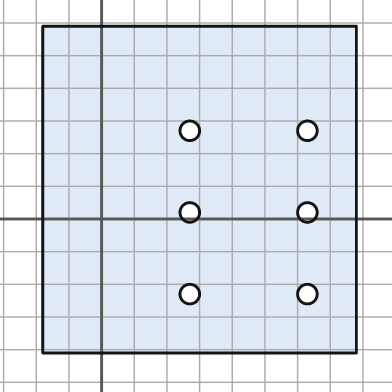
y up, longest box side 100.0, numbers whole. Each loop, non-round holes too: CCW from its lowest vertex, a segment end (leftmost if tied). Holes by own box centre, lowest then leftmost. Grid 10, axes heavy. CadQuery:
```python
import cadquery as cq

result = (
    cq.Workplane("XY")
    .moveTo(-18.0, -41.0)
    .lineTo(78.0, -41.0)
    .lineTo(78.0, 59.0)
    .lineTo(-18.0, 59.0)
    .close()
    .moveTo(27.0, -23.0)
    .circle(3.0)
    .moveTo(63.0, -23.0)
    .circle(3.0)
    .moveTo(27.0, 2.0)
    .circle(3.0)
    .moveTo(63.0, 2.0)
    .circle(3.0)
    .moveTo(27.0, 27.0)
    .circle(3.0)
    .moveTo(63.0, 27.0)
    .circle(3.0)
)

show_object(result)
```